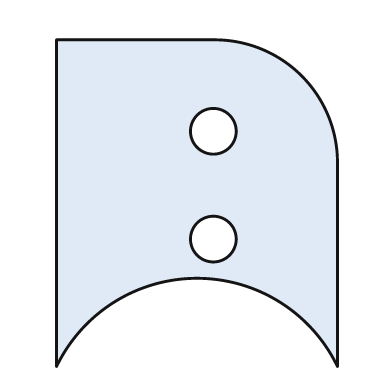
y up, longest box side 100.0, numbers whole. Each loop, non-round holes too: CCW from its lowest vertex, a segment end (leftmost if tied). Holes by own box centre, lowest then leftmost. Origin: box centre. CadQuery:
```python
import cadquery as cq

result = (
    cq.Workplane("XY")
    .moveTo(-43.0, -50.0)
    .threePointArc((0.0, -23.0), (43.0, -50.0))
    .lineTo(43.0, 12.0)
    .threePointArc((32.0, 39.0), (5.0, 50.0))
    .lineTo(-43.0, 50.0)
    .close()
    .moveTo(5.0, -11.0)
    .circle(7.0)
    .moveTo(5.0, 22.0)
    .circle(7.0)
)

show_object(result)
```